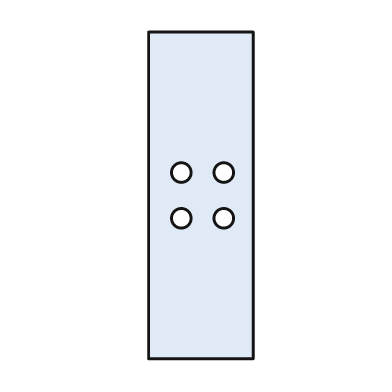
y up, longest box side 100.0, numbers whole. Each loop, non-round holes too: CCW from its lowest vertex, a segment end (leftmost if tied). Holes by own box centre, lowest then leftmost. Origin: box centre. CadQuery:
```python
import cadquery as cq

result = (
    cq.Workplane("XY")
    .moveTo(-16.0, -50.0)
    .lineTo(16.0, -50.0)
    .lineTo(16.0, 50.0)
    .lineTo(-16.0, 50.0)
    .close()
    .moveTo(-6.0, -7.0)
    .circle(3.0)
    .moveTo(7.0, -7.0)
    .circle(3.0)
    .moveTo(-6.0, 7.0)
    .circle(3.0)
    .moveTo(7.0, 7.0)
    .circle(3.0)
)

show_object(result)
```